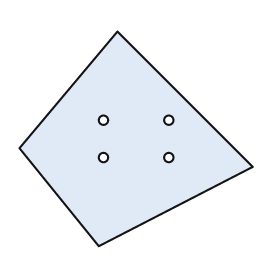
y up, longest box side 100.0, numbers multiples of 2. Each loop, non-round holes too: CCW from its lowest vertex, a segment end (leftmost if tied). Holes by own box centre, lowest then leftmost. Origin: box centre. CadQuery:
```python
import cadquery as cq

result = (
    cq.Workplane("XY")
    .moveTo(-16.0, -46.0)
    .lineTo(50.0, -12.0)
    .lineTo(-8.0, 46.0)
    .lineTo(-50.0, -4.0)
    .close()
    .moveTo(-14.0, -8.0)
    .circle(2.0)
    .moveTo(14.0, -8.0)
    .circle(2.0)
    .moveTo(-14.0, 8.0)
    .circle(2.0)
    .moveTo(14.0, 8.0)
    .circle(2.0)
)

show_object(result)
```